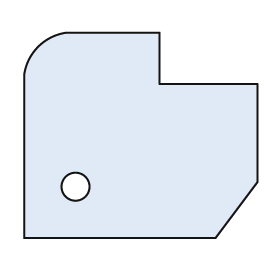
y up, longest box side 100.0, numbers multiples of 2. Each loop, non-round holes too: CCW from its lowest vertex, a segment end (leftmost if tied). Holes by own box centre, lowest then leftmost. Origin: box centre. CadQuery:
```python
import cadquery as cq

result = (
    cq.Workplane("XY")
    .moveTo(-50.0, -44.0)
    .lineTo(32.0, -44.0)
    .lineTo(50.0, -20.0)
    .lineTo(50.0, 22.0)
    .lineTo(8.0, 22.0)
    .lineTo(8.0, 44.0)
    .lineTo(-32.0, 44.0)
    .threePointArc((-44.0, 38.0), (-50.0, 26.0))
    .close()
    .moveTo(-28.0, -22.0)
    .circle(6.0)
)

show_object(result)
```